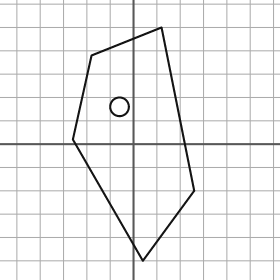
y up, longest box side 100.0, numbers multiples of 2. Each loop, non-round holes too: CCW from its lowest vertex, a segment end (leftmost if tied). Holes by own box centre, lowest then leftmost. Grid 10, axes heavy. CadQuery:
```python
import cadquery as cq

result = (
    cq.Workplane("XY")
    .moveTo(4.0, -50.0)
    .lineTo(26.0, -20.0)
    .lineTo(12.0, 50.0)
    .lineTo(-18.0, 38.0)
    .lineTo(-26.0, 2.0)
    .close()
    .moveTo(-6.0, 16.0)
    .circle(4.0)
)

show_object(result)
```